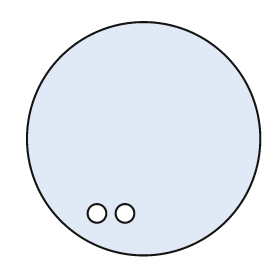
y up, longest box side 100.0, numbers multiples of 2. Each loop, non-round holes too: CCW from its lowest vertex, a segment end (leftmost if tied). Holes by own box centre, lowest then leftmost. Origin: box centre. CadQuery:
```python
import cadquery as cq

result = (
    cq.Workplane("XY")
    .moveTo(0.0, 0.0)
    .circle(50.0)
    .moveTo(-20.0, -32.0)
    .circle(4.0)
    .moveTo(-8.0, -32.0)
    .circle(4.0)
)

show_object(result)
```